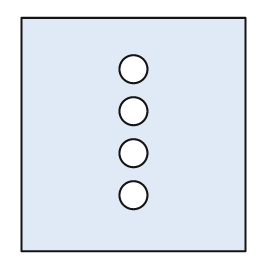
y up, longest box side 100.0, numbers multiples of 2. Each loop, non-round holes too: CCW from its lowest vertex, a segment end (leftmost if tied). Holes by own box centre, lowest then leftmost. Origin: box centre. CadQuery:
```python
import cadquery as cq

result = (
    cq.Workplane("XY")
    .moveTo(-48.0, -50.0)
    .lineTo(48.0, -50.0)
    .lineTo(48.0, 50.0)
    .lineTo(-48.0, 50.0)
    .close()
    .moveTo(0.0, -26.0)
    .circle(6.0)
    .moveTo(0.0, -8.0)
    .circle(6.0)
    .moveTo(0.0, 10.0)
    .circle(6.0)
    .moveTo(0.0, 28.0)
    .circle(6.0)
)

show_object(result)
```